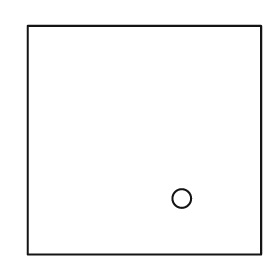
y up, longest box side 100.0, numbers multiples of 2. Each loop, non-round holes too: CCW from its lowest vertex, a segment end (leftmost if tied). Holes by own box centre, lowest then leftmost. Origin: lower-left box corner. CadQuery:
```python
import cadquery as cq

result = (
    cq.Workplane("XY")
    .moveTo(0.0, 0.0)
    .lineTo(100.0, 0.0)
    .lineTo(100.0, 98.0)
    .lineTo(0.0, 98.0)
    .close()
    .moveTo(66.0, 24.0)
    .circle(4.0)
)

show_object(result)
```